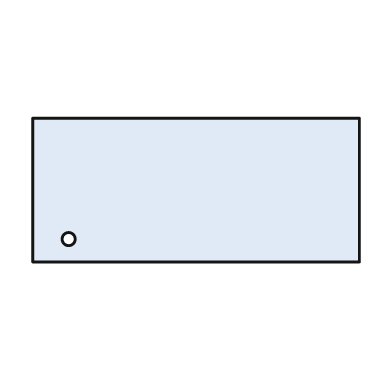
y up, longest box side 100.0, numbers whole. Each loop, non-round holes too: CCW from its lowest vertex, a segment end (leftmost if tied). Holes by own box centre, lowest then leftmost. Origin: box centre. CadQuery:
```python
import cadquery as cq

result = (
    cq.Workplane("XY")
    .moveTo(-50.0, -22.0)
    .lineTo(50.0, -22.0)
    .lineTo(50.0, 22.0)
    .lineTo(-50.0, 22.0)
    .close()
    .moveTo(-39.0, -15.0)
    .circle(2.0)
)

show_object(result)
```